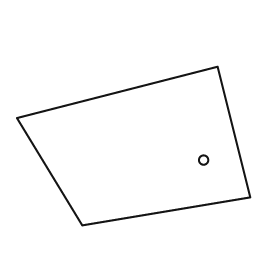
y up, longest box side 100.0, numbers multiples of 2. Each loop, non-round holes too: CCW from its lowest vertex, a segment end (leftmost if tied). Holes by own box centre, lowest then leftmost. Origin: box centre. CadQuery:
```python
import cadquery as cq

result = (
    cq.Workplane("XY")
    .moveTo(-22.0, -34.0)
    .lineTo(50.0, -22.0)
    .lineTo(36.0, 34.0)
    .lineTo(-50.0, 12.0)
    .close()
    .moveTo(30.0, -6.0)
    .circle(2.0)
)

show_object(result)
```